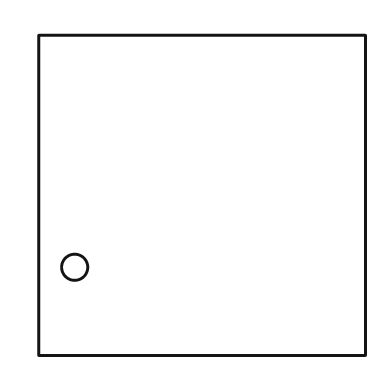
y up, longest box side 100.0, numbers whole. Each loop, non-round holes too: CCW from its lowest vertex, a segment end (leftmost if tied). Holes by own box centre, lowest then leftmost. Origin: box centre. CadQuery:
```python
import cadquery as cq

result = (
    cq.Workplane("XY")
    .moveTo(-50.0, -49.0)
    .lineTo(50.0, -49.0)
    .lineTo(50.0, 49.0)
    .lineTo(-50.0, 49.0)
    .close()
    .moveTo(-39.0, -22.0)
    .circle(4.0)
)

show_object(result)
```